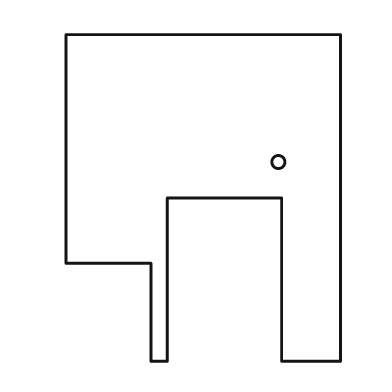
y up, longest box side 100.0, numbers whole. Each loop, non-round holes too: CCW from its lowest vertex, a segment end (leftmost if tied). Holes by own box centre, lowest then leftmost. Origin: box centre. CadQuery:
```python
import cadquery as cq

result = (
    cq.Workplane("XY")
    .moveTo(-16.0, -50.0)
    .lineTo(-11.0, -50.0)
    .lineTo(-11.0, 0.0)
    .lineTo(24.0, 0.0)
    .lineTo(24.0, -50.0)
    .lineTo(42.0, -50.0)
    .lineTo(42.0, 50.0)
    .lineTo(-42.0, 50.0)
    .lineTo(-42.0, -20.0)
    .lineTo(-16.0, -20.0)
    .close()
    .moveTo(23.0, 11.0)
    .circle(2.0)
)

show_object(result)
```